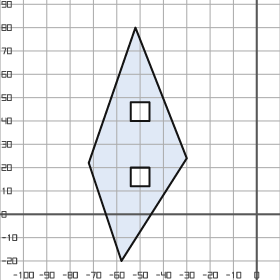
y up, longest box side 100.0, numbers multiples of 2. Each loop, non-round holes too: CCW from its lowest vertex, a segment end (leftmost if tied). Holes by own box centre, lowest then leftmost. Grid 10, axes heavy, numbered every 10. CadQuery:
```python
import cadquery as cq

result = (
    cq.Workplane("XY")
    .moveTo(-58.0, -20.0)
    .lineTo(-30.0, 24.0)
    .lineTo(-52.0, 80.0)
    .lineTo(-72.0, 22.0)
    .close()
    .moveTo(-54.0, 12.0)
    .lineTo(-46.0, 12.0)
    .lineTo(-46.0, 20.0)
    .lineTo(-54.0, 20.0)
    .close()
    .moveTo(-54.0, 40.0)
    .lineTo(-46.0, 40.0)
    .lineTo(-46.0, 48.0)
    .lineTo(-54.0, 48.0)
    .close()
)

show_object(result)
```